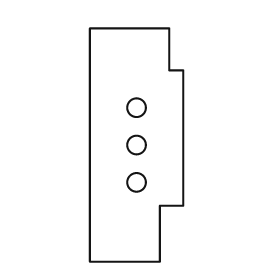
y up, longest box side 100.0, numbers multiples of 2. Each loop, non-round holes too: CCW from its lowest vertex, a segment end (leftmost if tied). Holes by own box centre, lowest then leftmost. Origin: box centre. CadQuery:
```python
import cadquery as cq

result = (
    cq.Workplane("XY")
    .moveTo(-20.0, -50.0)
    .lineTo(10.0, -50.0)
    .lineTo(10.0, -26.0)
    .lineTo(20.0, -26.0)
    .lineTo(20.0, 32.0)
    .lineTo(14.0, 32.0)
    .lineTo(14.0, 50.0)
    .lineTo(-20.0, 50.0)
    .close()
    .moveTo(0.0, -16.0)
    .circle(4.0)
    .moveTo(0.0, 0.0)
    .circle(4.0)
    .moveTo(0.0, 16.0)
    .circle(4.0)
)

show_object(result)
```